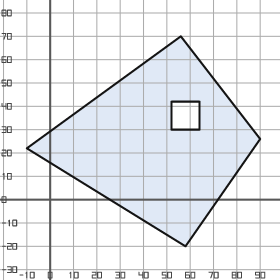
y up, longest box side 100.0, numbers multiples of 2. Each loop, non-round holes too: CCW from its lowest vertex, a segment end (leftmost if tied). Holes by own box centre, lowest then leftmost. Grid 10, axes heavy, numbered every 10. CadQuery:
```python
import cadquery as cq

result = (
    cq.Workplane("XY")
    .moveTo(58.0, -20.0)
    .lineTo(90.0, 26.0)
    .lineTo(56.0, 70.0)
    .lineTo(-10.0, 22.0)
    .close()
    .moveTo(52.0, 30.0)
    .lineTo(64.0, 30.0)
    .lineTo(64.0, 42.0)
    .lineTo(52.0, 42.0)
    .close()
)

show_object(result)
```